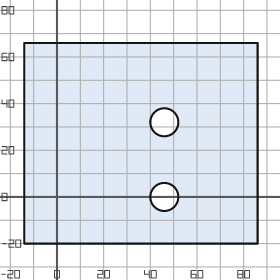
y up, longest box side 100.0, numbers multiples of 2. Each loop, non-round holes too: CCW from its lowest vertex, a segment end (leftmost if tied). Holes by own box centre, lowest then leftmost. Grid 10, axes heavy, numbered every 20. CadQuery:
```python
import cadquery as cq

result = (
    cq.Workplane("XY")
    .moveTo(-14.0, -20.0)
    .lineTo(86.0, -20.0)
    .lineTo(86.0, 66.0)
    .lineTo(-14.0, 66.0)
    .close()
    .moveTo(46.0, 0.0)
    .circle(6.0)
    .moveTo(46.0, 32.0)
    .circle(6.0)
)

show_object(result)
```